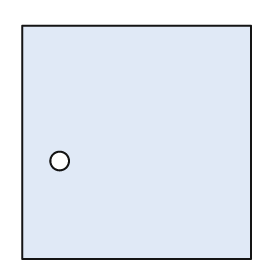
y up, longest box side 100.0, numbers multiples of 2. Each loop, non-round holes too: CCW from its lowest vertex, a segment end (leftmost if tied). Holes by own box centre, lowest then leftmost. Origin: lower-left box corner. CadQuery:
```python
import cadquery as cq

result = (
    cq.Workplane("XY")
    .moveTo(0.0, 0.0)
    .lineTo(98.0, 0.0)
    .lineTo(98.0, 100.0)
    .lineTo(0.0, 100.0)
    .close()
    .moveTo(16.0, 42.0)
    .circle(4.0)
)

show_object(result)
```